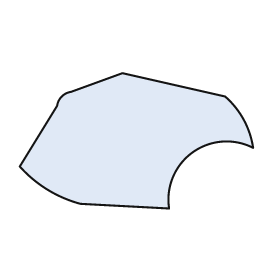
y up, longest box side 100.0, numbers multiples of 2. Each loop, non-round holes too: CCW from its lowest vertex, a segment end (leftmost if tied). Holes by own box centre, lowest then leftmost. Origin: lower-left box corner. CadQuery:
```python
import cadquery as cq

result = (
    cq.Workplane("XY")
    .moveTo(64.0, 0.0)
    .threePointArc((74.0, 24.0), (100.0, 26.0))
    .threePointArc((96.0, 38.0), (88.0, 48.0))
    .lineTo(44.0, 58.0)
    .lineTo(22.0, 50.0)
    .threePointArc((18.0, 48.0), (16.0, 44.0))
    .lineTo(0.0, 18.0)
    .threePointArc((12.0, 8.0), (26.0, 2.0))
    .close()
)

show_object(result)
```